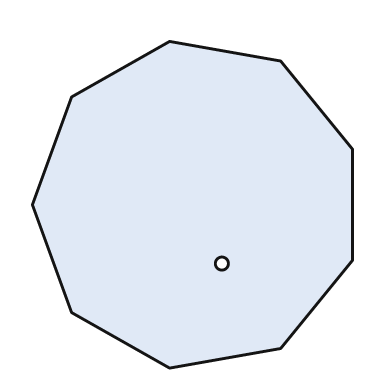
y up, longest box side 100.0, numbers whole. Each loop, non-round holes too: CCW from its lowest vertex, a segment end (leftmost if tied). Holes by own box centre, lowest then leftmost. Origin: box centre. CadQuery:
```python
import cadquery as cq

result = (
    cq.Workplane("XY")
    .moveTo(-7.0, -50.0)
    .lineTo(27.0, -44.0)
    .lineTo(49.0, -17.0)
    .lineTo(49.0, 17.0)
    .lineTo(27.0, 44.0)
    .lineTo(-7.0, 50.0)
    .lineTo(-37.0, 33.0)
    .lineTo(-49.0, 0.0)
    .lineTo(-37.0, -33.0)
    .close()
    .moveTo(9.0, -18.0)
    .circle(2.0)
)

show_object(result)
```